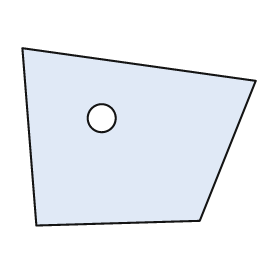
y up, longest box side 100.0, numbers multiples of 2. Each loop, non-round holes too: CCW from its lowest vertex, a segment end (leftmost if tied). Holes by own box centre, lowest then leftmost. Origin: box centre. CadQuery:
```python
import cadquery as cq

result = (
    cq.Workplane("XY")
    .moveTo(-44.0, -38.0)
    .lineTo(26.0, -36.0)
    .lineTo(50.0, 24.0)
    .lineTo(-50.0, 38.0)
    .close()
    .moveTo(-16.0, 8.0)
    .circle(6.0)
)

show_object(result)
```